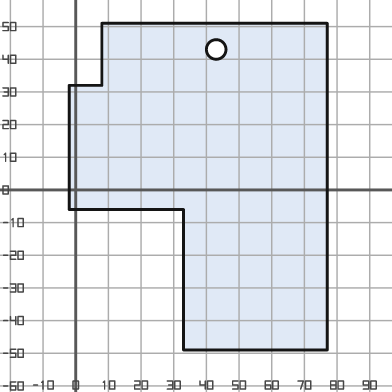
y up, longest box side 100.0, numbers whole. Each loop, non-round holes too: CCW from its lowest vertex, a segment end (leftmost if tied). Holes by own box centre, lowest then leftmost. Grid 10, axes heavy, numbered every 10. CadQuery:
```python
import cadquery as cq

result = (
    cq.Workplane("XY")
    .moveTo(33.0, -49.0)
    .lineTo(77.0, -49.0)
    .lineTo(77.0, 51.0)
    .lineTo(8.0, 51.0)
    .lineTo(8.0, 32.0)
    .lineTo(-2.0, 32.0)
    .lineTo(-2.0, -6.0)
    .lineTo(33.0, -6.0)
    .close()
    .moveTo(43.0, 43.0)
    .circle(3.0)
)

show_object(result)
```